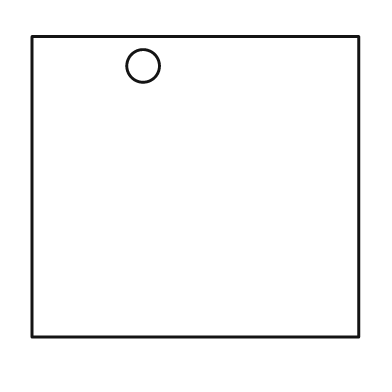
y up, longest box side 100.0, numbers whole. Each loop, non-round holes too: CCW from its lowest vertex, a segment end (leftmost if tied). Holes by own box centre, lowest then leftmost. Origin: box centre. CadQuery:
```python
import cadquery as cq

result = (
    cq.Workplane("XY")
    .moveTo(-50.0, -46.0)
    .lineTo(50.0, -46.0)
    .lineTo(50.0, 46.0)
    .lineTo(-50.0, 46.0)
    .close()
    .moveTo(-16.0, 37.0)
    .circle(5.0)
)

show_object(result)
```